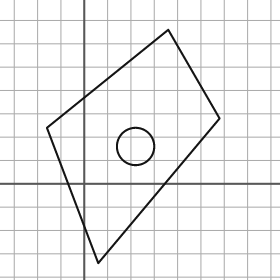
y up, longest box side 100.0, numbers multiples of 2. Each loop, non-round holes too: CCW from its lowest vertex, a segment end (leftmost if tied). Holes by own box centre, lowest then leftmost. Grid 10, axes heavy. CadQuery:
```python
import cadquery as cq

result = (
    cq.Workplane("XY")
    .moveTo(6.0, -34.0)
    .lineTo(58.0, 28.0)
    .lineTo(36.0, 66.0)
    .lineTo(-16.0, 24.0)
    .close()
    .moveTo(22.0, 16.0)
    .circle(8.0)
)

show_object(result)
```